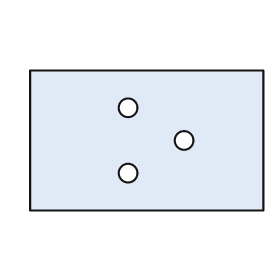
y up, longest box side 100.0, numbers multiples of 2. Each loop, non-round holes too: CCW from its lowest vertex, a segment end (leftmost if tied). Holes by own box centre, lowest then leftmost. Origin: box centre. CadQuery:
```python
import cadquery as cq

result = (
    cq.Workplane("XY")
    .moveTo(-50.0, -30.0)
    .lineTo(50.0, -30.0)
    .lineTo(50.0, 30.0)
    .lineTo(-50.0, 30.0)
    .close()
    .moveTo(-8.0, -14.0)
    .circle(4.0)
    .moveTo(16.0, 0.0)
    .circle(4.0)
    .moveTo(-8.0, 14.0)
    .circle(4.0)
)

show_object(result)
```